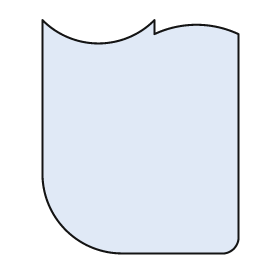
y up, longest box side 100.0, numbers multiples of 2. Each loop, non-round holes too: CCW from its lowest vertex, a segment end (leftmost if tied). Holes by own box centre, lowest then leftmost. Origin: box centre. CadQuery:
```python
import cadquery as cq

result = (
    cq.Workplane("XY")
    .moveTo(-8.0, -50.0)
    .lineTo(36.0, -50.0)
    .threePointArc((40.0, -48.0), (42.0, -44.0))
    .lineTo(42.0, 44.0)
    .threePointArc((24.0, 48.0), (6.0, 44.0))
    .lineTo(6.0, 50.0)
    .threePointArc((-18.0, 40.0), (-42.0, 50.0))
    .lineTo(-42.0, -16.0)
    .threePointArc((-32.0, -40.0), (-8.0, -50.0))
    .close()
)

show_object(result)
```